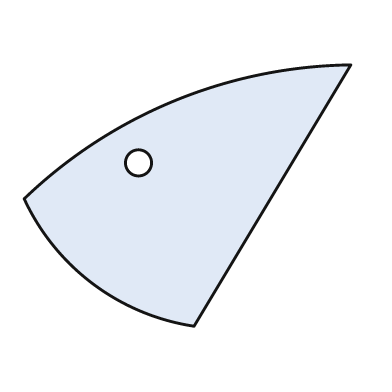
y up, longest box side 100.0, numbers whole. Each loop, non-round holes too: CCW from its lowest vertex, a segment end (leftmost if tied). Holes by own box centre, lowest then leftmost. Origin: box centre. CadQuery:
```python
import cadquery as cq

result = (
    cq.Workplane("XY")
    .moveTo(2.0, -40.0)
    .lineTo(50.0, 40.0)
    .threePointArc((-4.0, 29.0), (-50.0, -1.0))
    .threePointArc((-29.0, -27.0), (2.0, -40.0))
    .close()
    .moveTo(-15.0, 10.0)
    .circle(4.0)
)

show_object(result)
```